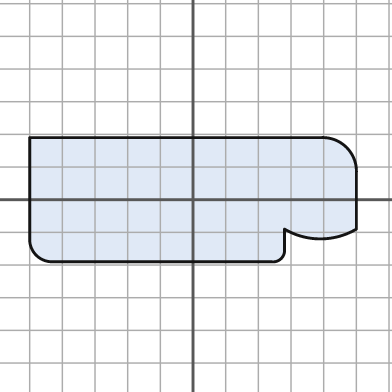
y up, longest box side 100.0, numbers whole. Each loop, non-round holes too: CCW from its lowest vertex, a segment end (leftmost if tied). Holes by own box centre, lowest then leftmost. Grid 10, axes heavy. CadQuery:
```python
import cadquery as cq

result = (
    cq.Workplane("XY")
    .moveTo(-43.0, -19.0)
    .lineTo(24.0, -19.0)
    .threePointArc((27.0, -18.0), (28.0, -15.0))
    .lineTo(28.0, -9.0)
    .threePointArc((39.0, -12.0), (50.0, -9.0))
    .lineTo(50.0, 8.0)
    .threePointArc((47.0, 16.0), (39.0, 19.0))
    .lineTo(-50.0, 19.0)
    .lineTo(-50.0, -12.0)
    .threePointArc((-48.0, -17.0), (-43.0, -19.0))
    .close()
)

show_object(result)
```